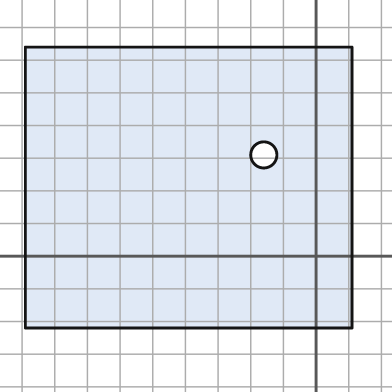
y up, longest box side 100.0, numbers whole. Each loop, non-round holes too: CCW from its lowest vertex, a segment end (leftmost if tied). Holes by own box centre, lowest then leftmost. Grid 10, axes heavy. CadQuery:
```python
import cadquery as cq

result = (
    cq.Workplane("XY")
    .moveTo(-89.0, -22.0)
    .lineTo(11.0, -22.0)
    .lineTo(11.0, 64.0)
    .lineTo(-89.0, 64.0)
    .close()
    .moveTo(-16.0, 31.0)
    .circle(4.0)
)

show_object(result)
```